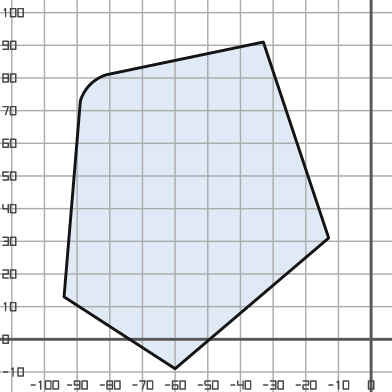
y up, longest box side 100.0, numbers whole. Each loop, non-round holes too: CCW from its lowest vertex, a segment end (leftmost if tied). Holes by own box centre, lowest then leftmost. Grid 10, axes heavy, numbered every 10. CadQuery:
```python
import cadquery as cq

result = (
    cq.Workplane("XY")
    .moveTo(-60.0, -9.0)
    .lineTo(-13.0, 31.0)
    .lineTo(-33.0, 91.0)
    .lineTo(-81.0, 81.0)
    .threePointArc((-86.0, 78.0), (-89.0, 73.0))
    .lineTo(-94.0, 13.0)
    .close()
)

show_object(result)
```